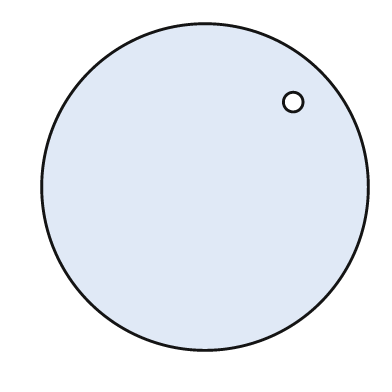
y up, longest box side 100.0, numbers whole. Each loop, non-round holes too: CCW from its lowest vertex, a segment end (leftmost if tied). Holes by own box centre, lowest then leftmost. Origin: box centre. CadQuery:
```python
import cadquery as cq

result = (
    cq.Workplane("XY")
    .moveTo(0.0, 0.0)
    .circle(50.0)
    .moveTo(27.0, 26.0)
    .circle(3.0)
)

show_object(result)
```